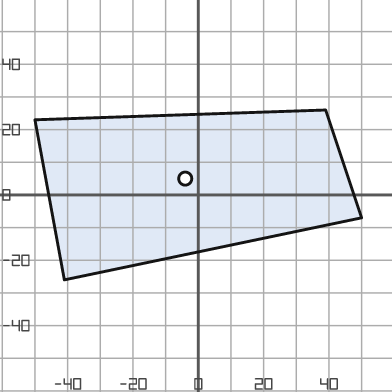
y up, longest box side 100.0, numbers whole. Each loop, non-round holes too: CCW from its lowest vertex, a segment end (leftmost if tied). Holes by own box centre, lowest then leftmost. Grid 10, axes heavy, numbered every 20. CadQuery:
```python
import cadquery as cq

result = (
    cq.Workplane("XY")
    .moveTo(-41.0, -26.0)
    .lineTo(50.0, -7.0)
    .lineTo(39.0, 26.0)
    .lineTo(-50.0, 23.0)
    .close()
    .moveTo(-4.0, 5.0)
    .circle(2.0)
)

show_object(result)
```